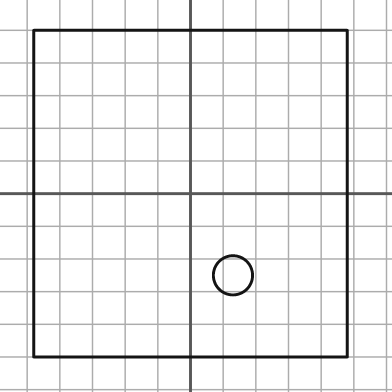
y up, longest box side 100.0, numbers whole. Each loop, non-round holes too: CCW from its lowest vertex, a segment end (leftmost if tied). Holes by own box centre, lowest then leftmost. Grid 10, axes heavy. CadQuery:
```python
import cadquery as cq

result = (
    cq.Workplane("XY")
    .moveTo(-48.0, -50.0)
    .lineTo(48.0, -50.0)
    .lineTo(48.0, 50.0)
    .lineTo(-48.0, 50.0)
    .close()
    .moveTo(13.0, -25.0)
    .circle(6.0)
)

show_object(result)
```